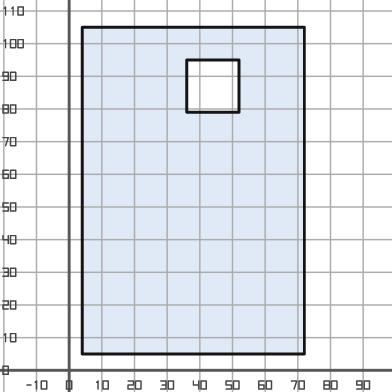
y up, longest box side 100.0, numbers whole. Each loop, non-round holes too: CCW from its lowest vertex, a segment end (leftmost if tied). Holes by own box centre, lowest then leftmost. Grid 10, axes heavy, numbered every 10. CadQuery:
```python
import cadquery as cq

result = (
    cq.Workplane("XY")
    .moveTo(4.0, 5.0)
    .lineTo(72.0, 5.0)
    .lineTo(72.0, 105.0)
    .lineTo(4.0, 105.0)
    .close()
    .moveTo(36.0, 79.0)
    .lineTo(52.0, 79.0)
    .lineTo(52.0, 95.0)
    .lineTo(36.0, 95.0)
    .close()
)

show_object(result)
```